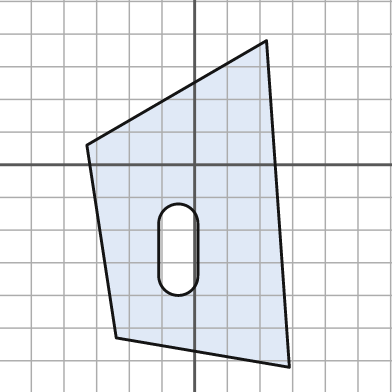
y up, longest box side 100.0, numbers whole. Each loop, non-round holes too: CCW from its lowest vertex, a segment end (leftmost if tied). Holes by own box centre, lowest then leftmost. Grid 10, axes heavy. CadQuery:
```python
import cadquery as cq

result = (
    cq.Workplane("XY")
    .moveTo(29.0, -62.0)
    .lineTo(22.0, 38.0)
    .lineTo(-33.0, 6.0)
    .lineTo(-24.0, -53.0)
    .close()
    .moveTo(-11.0, -34.0)
    .threePointArc((-5.0, -40.0), (1.0, -34.0))
    .lineTo(1.0, -18.0)
    .threePointArc((-5.0, -12.0), (-11.0, -18.0))
    .close()
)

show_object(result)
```